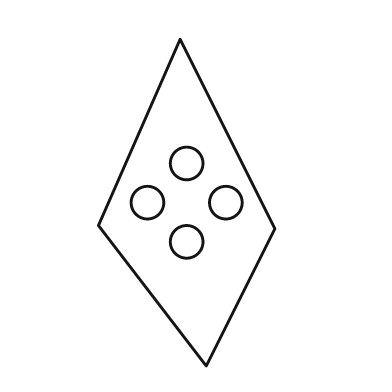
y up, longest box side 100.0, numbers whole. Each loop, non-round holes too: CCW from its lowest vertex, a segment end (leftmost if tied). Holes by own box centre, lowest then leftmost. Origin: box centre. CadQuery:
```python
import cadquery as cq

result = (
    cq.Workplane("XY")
    .moveTo(6.0, -50.0)
    .lineTo(27.0, -8.0)
    .lineTo(-2.0, 50.0)
    .lineTo(-27.0, -7.0)
    .close()
    .moveTo(0.0, -12.0)
    .circle(5.0)
    .moveTo(-12.0, 0.0)
    .circle(5.0)
    .moveTo(12.0, 0.0)
    .circle(5.0)
    .moveTo(0.0, 12.0)
    .circle(5.0)
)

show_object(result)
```